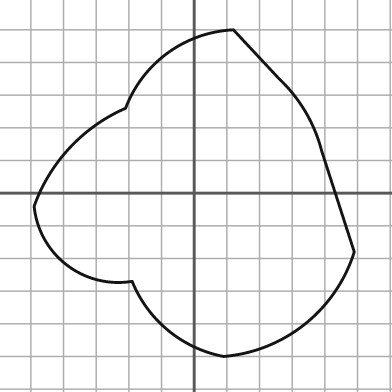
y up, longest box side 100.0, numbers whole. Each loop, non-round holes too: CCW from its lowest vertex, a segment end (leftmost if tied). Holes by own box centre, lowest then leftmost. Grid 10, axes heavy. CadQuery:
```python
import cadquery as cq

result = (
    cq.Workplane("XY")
    .moveTo(9.0, -50.0)
    .threePointArc((34.0, -40.0), (49.0, -18.0))
    .lineTo(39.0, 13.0)
    .threePointArc((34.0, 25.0), (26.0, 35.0))
    .lineTo(12.0, 50.0)
    .threePointArc((-8.0, 43.0), (-21.0, 26.0))
    .threePointArc((-38.0, 14.0), (-49.0, -4.0))
    .threePointArc((-39.0, -22.0), (-19.0, -27.0))
    .threePointArc((-8.0, -42.0), (9.0, -50.0))
    .close()
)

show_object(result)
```